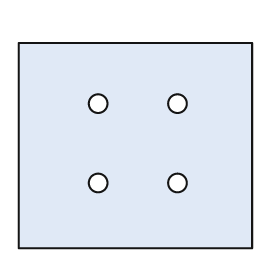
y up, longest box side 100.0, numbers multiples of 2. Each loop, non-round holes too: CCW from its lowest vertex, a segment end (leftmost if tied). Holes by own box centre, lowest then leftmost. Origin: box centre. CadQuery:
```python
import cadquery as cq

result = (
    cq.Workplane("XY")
    .moveTo(-50.0, -44.0)
    .lineTo(50.0, -44.0)
    .lineTo(50.0, 44.0)
    .lineTo(-50.0, 44.0)
    .close()
    .moveTo(-16.0, -16.0)
    .circle(4.0)
    .moveTo(18.0, -16.0)
    .circle(4.0)
    .moveTo(-16.0, 18.0)
    .circle(4.0)
    .moveTo(18.0, 18.0)
    .circle(4.0)
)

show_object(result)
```